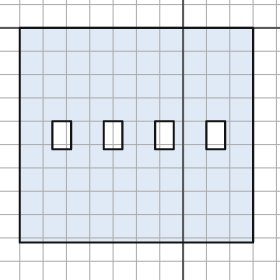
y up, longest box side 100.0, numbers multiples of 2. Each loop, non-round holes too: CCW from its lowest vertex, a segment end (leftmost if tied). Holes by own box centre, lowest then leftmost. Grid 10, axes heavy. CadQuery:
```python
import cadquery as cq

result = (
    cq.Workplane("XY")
    .moveTo(-70.0, -92.0)
    .lineTo(30.0, -92.0)
    .lineTo(30.0, 0.0)
    .lineTo(-70.0, 0.0)
    .close()
    .moveTo(-56.0, -52.0)
    .lineTo(-48.0, -52.0)
    .lineTo(-48.0, -40.0)
    .lineTo(-56.0, -40.0)
    .close()
    .moveTo(-34.0, -52.0)
    .lineTo(-26.0, -52.0)
    .lineTo(-26.0, -40.0)
    .lineTo(-34.0, -40.0)
    .close()
    .moveTo(-12.0, -52.0)
    .lineTo(-4.0, -52.0)
    .lineTo(-4.0, -40.0)
    .lineTo(-12.0, -40.0)
    .close()
    .moveTo(10.0, -52.0)
    .lineTo(18.0, -52.0)
    .lineTo(18.0, -40.0)
    .lineTo(10.0, -40.0)
    .close()
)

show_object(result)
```